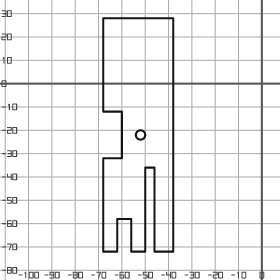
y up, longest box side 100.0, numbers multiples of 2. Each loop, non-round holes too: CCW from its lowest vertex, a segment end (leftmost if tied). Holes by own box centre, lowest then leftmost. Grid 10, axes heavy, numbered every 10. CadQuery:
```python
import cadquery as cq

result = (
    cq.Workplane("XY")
    .moveTo(-68.0, -72.0)
    .lineTo(-62.0, -72.0)
    .lineTo(-62.0, -58.0)
    .lineTo(-56.0, -58.0)
    .lineTo(-56.0, -72.0)
    .lineTo(-50.0, -72.0)
    .lineTo(-50.0, -36.0)
    .lineTo(-46.0, -36.0)
    .lineTo(-46.0, -72.0)
    .lineTo(-38.0, -72.0)
    .lineTo(-38.0, 28.0)
    .lineTo(-68.0, 28.0)
    .lineTo(-68.0, -12.0)
    .lineTo(-60.0, -12.0)
    .lineTo(-60.0, -32.0)
    .lineTo(-68.0, -32.0)
    .close()
    .moveTo(-52.0, -22.0)
    .circle(2.0)
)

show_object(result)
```